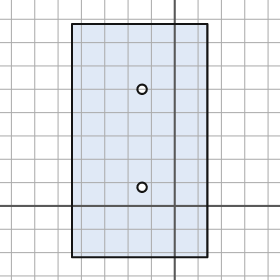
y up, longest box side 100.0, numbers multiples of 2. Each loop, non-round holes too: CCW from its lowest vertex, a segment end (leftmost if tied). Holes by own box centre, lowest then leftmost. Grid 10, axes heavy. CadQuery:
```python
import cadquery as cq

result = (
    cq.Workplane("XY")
    .moveTo(-44.0, -22.0)
    .lineTo(14.0, -22.0)
    .lineTo(14.0, 78.0)
    .lineTo(-44.0, 78.0)
    .close()
    .moveTo(-14.0, 8.0)
    .circle(2.0)
    .moveTo(-14.0, 50.0)
    .circle(2.0)
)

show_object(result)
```